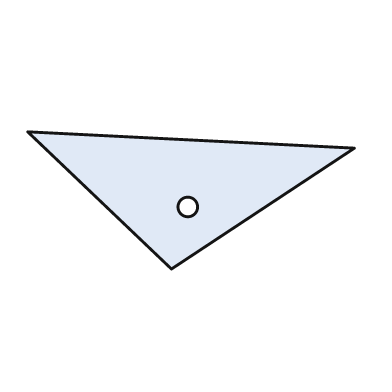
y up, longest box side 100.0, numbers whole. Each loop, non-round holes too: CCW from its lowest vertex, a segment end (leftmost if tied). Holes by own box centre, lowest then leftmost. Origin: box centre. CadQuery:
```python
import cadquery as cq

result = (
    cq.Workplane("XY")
    .moveTo(-6.0, -21.0)
    .lineTo(50.0, 16.0)
    .lineTo(-50.0, 21.0)
    .close()
    .moveTo(-1.0, -2.0)
    .circle(3.0)
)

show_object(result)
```